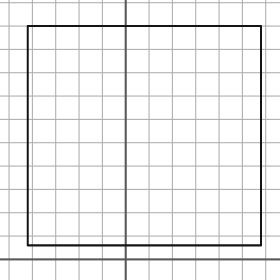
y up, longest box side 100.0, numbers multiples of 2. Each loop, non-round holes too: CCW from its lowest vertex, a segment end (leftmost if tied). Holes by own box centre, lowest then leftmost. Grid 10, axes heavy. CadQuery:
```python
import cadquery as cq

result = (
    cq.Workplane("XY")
    .moveTo(-42.0, 6.0)
    .lineTo(58.0, 6.0)
    .lineTo(58.0, 100.0)
    .lineTo(-42.0, 100.0)
    .close()
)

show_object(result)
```